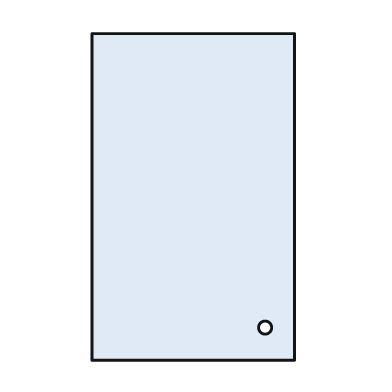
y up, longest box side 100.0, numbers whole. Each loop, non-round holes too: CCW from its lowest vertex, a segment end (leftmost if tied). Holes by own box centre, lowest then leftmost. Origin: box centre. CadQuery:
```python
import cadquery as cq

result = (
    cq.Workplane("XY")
    .moveTo(-31.0, -50.0)
    .lineTo(31.0, -50.0)
    .lineTo(31.0, 50.0)
    .lineTo(-31.0, 50.0)
    .close()
    .moveTo(22.0, -40.0)
    .circle(2.0)
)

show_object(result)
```